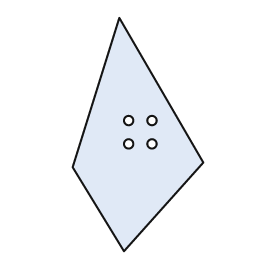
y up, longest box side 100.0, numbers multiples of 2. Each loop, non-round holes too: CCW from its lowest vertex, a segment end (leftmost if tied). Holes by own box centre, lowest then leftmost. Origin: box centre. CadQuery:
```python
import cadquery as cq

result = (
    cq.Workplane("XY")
    .moveTo(-6.0, -50.0)
    .lineTo(28.0, -12.0)
    .lineTo(-8.0, 50.0)
    .lineTo(-28.0, -14.0)
    .close()
    .moveTo(-4.0, -4.0)
    .circle(2.0)
    .moveTo(6.0, -4.0)
    .circle(2.0)
    .moveTo(-4.0, 6.0)
    .circle(2.0)
    .moveTo(6.0, 6.0)
    .circle(2.0)
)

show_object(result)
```